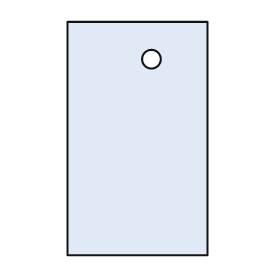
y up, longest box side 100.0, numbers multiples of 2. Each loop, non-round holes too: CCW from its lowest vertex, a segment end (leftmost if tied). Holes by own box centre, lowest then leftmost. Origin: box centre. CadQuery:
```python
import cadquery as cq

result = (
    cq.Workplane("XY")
    .moveTo(-30.0, -50.0)
    .lineTo(30.0, -50.0)
    .lineTo(30.0, 50.0)
    .lineTo(-30.0, 50.0)
    .close()
    .moveTo(6.0, 34.0)
    .circle(4.0)
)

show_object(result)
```